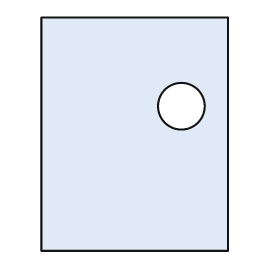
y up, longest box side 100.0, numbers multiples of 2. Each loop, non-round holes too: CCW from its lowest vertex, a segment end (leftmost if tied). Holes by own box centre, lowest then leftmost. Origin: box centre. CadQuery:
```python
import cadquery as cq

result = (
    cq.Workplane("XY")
    .moveTo(-40.0, -50.0)
    .lineTo(40.0, -50.0)
    .lineTo(40.0, 50.0)
    .lineTo(-40.0, 50.0)
    .close()
    .moveTo(20.0, 12.0)
    .circle(10.0)
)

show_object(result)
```